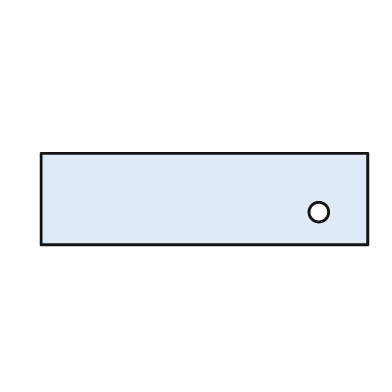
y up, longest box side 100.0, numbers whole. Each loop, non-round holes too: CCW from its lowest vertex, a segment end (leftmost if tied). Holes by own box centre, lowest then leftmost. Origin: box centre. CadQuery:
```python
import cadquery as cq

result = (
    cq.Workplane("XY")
    .moveTo(-50.0, -14.0)
    .lineTo(50.0, -14.0)
    .lineTo(50.0, 14.0)
    .lineTo(-50.0, 14.0)
    .close()
    .moveTo(35.0, -4.0)
    .circle(3.0)
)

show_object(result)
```